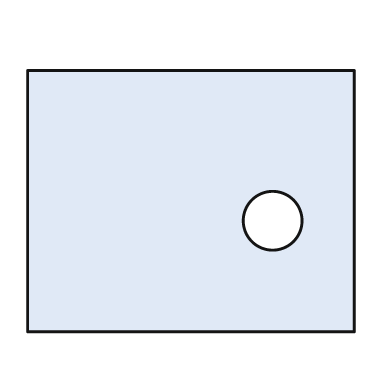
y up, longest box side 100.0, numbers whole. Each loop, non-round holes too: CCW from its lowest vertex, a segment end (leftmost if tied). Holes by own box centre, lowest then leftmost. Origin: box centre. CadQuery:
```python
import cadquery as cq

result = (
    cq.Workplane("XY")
    .moveTo(-50.0, -40.0)
    .lineTo(50.0, -40.0)
    .lineTo(50.0, 40.0)
    .lineTo(-50.0, 40.0)
    .close()
    .moveTo(25.0, -6.0)
    .circle(9.0)
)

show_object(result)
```